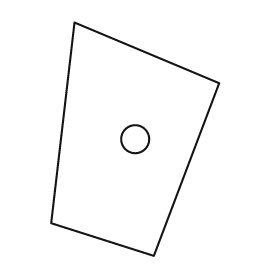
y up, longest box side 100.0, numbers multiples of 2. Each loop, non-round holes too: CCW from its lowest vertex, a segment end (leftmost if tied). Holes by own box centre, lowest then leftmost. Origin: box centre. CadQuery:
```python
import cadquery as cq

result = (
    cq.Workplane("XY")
    .moveTo(8.0, -50.0)
    .lineTo(36.0, 24.0)
    .lineTo(-26.0, 50.0)
    .lineTo(-36.0, -36.0)
    .close()
    .moveTo(0.0, 0.0)
    .circle(6.0)
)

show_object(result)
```